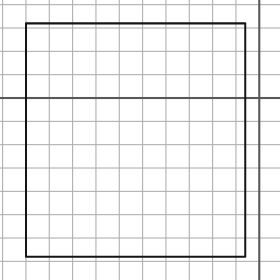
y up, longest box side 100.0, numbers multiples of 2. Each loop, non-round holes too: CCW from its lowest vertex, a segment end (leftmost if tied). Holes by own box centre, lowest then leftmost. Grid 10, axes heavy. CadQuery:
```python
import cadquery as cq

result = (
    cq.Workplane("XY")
    .moveTo(-100.0, -68.0)
    .lineTo(-6.0, -68.0)
    .lineTo(-6.0, 32.0)
    .lineTo(-100.0, 32.0)
    .close()
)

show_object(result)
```